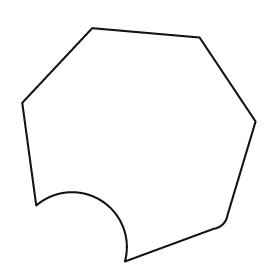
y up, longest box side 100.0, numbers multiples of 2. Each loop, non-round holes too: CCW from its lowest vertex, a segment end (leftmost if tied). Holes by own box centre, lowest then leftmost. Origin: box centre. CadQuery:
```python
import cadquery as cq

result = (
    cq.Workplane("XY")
    .moveTo(-6.0, -50.0)
    .lineTo(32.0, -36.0)
    .threePointArc((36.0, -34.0), (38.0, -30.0))
    .lineTo(50.0, 10.0)
    .lineTo(26.0, 46.0)
    .lineTo(-20.0, 50.0)
    .lineTo(-50.0, 18.0)
    .lineTo(-44.0, -26.0)
    .threePointArc((-16.0, -24.0), (-6.0, -50.0))
    .close()
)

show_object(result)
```